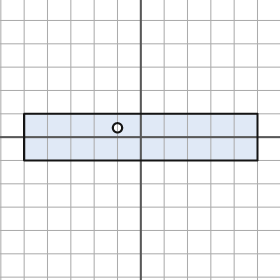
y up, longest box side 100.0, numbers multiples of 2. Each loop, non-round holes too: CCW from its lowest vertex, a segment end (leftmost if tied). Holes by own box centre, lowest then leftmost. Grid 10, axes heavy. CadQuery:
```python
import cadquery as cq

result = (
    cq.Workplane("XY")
    .moveTo(-50.0, -10.0)
    .lineTo(50.0, -10.0)
    .lineTo(50.0, 10.0)
    .lineTo(-50.0, 10.0)
    .close()
    .moveTo(-10.0, 4.0)
    .circle(2.0)
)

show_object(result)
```